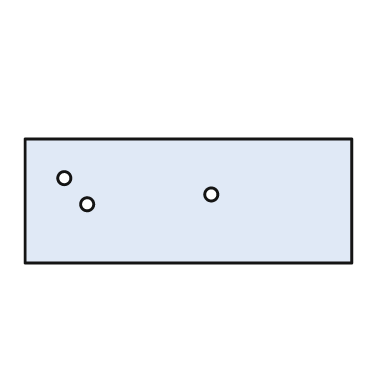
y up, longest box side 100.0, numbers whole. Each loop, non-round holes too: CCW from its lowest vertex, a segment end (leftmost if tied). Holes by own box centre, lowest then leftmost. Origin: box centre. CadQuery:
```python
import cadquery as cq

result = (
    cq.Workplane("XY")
    .moveTo(-50.0, -19.0)
    .lineTo(50.0, -19.0)
    .lineTo(50.0, 19.0)
    .lineTo(-50.0, 19.0)
    .close()
    .moveTo(-31.0, -1.0)
    .circle(2.0)
    .moveTo(7.0, 2.0)
    .circle(2.0)
    .moveTo(-38.0, 7.0)
    .circle(2.0)
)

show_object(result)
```